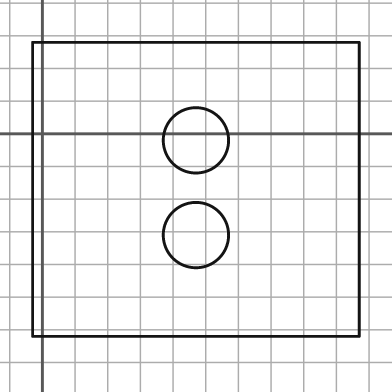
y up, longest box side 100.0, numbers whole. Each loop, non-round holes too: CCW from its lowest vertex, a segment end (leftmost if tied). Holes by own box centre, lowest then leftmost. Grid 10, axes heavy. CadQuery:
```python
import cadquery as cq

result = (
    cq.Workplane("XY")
    .moveTo(-3.0, -62.0)
    .lineTo(97.0, -62.0)
    .lineTo(97.0, 28.0)
    .lineTo(-3.0, 28.0)
    .close()
    .moveTo(47.0, -31.0)
    .circle(10.0)
    .moveTo(47.0, -2.0)
    .circle(10.0)
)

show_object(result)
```